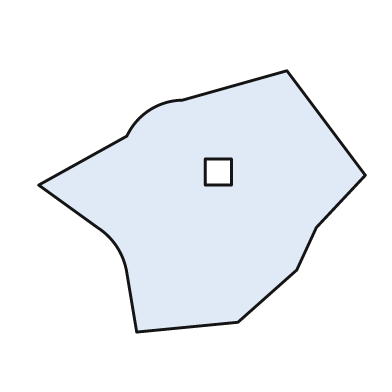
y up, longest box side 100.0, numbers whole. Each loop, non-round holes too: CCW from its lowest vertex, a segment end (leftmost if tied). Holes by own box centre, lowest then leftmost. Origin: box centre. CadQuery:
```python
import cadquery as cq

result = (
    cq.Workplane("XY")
    .moveTo(-20.0, -40.0)
    .lineTo(11.0, -37.0)
    .lineTo(29.0, -21.0)
    .lineTo(35.0, -8.0)
    .lineTo(50.0, 8.0)
    .lineTo(26.0, 40.0)
    .lineTo(-6.0, 31.0)
    .threePointArc((-16.0, 28.0), (-23.0, 20.0))
    .lineTo(-50.0, 5.0)
    .lineTo(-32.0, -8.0)
    .threePointArc((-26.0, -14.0), (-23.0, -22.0))
    .close()
    .moveTo(1.0, 5.0)
    .lineTo(9.0, 5.0)
    .lineTo(9.0, 13.0)
    .lineTo(1.0, 13.0)
    .close()
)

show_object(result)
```